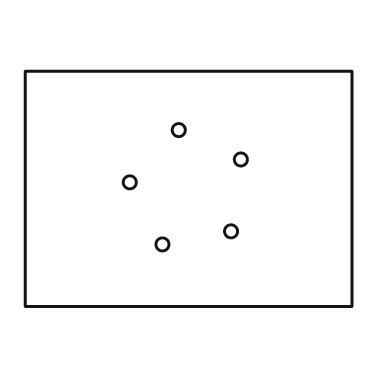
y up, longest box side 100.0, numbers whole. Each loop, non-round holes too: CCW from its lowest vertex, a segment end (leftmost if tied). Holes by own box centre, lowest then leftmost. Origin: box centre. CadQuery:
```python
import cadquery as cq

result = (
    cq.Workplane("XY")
    .moveTo(-50.0, -36.0)
    .lineTo(50.0, -36.0)
    .lineTo(50.0, 36.0)
    .lineTo(-50.0, 36.0)
    .close()
    .moveTo(-8.0, -17.0)
    .circle(2.0)
    .moveTo(13.0, -13.0)
    .circle(2.0)
    .moveTo(-18.0, 2.0)
    .circle(2.0)
    .moveTo(16.0, 9.0)
    .circle(2.0)
    .moveTo(-3.0, 18.0)
    .circle(2.0)
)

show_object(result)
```